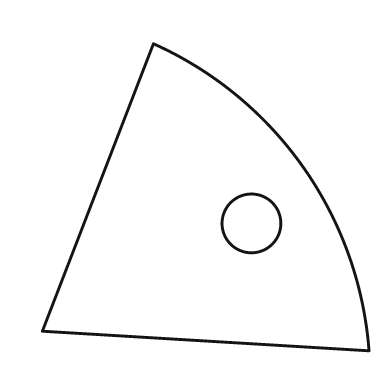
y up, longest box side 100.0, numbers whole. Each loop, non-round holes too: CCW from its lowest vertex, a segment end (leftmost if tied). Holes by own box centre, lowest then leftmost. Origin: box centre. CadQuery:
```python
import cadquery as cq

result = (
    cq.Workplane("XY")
    .moveTo(50.0, -47.0)
    .threePointArc((30.0, 9.0), (-16.0, 47.0))
    .lineTo(-50.0, -41.0)
    .close()
    .moveTo(14.0, -8.0)
    .circle(9.0)
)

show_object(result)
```